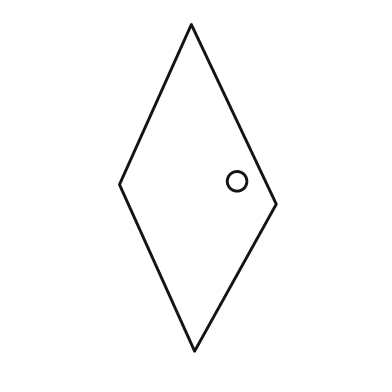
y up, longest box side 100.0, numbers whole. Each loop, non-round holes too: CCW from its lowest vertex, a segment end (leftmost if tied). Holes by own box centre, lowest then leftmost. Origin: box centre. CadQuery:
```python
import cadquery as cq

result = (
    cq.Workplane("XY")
    .moveTo(-1.0, -50.0)
    .lineTo(24.0, -5.0)
    .lineTo(-2.0, 50.0)
    .lineTo(-24.0, 1.0)
    .close()
    .moveTo(12.0, 2.0)
    .circle(3.0)
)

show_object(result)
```